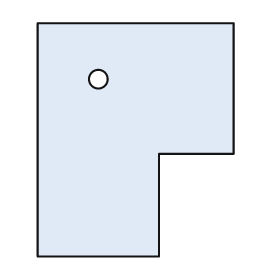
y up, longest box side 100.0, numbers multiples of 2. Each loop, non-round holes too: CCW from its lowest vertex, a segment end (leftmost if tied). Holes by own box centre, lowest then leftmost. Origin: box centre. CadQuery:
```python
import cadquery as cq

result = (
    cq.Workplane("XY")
    .moveTo(-42.0, -50.0)
    .lineTo(10.0, -50.0)
    .lineTo(10.0, -6.0)
    .lineTo(42.0, -6.0)
    .lineTo(42.0, 50.0)
    .lineTo(-42.0, 50.0)
    .close()
    .moveTo(-16.0, 26.0)
    .circle(4.0)
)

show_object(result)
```